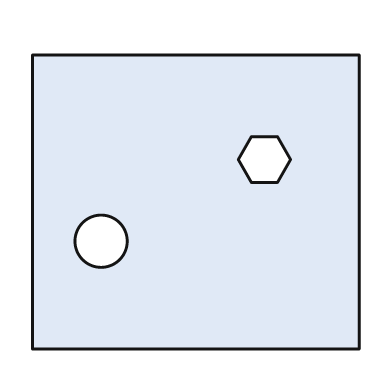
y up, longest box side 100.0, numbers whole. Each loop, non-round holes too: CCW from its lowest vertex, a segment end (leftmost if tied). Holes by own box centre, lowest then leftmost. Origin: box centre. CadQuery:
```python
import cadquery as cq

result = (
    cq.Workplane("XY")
    .moveTo(-50.0, -45.0)
    .lineTo(50.0, -45.0)
    .lineTo(50.0, 45.0)
    .lineTo(-50.0, 45.0)
    .close()
    .moveTo(-29.0, -12.0)
    .circle(8.0)
    .moveTo(17.0, 6.0)
    .lineTo(25.0, 6.0)
    .lineTo(29.0, 13.0)
    .lineTo(25.0, 20.0)
    .lineTo(17.0, 20.0)
    .lineTo(13.0, 13.0)
    .close()
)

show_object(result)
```